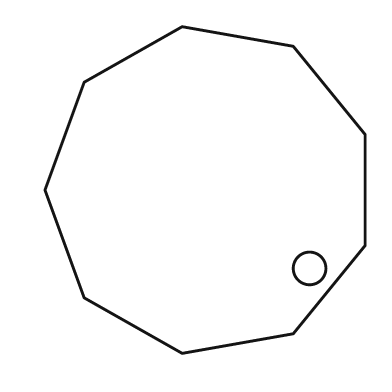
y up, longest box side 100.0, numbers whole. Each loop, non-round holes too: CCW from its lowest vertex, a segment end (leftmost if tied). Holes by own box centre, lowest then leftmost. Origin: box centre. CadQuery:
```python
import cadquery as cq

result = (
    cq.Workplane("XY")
    .moveTo(-7.0, -50.0)
    .lineTo(27.0, -44.0)
    .lineTo(49.0, -17.0)
    .lineTo(49.0, 17.0)
    .lineTo(27.0, 44.0)
    .lineTo(-7.0, 50.0)
    .lineTo(-37.0, 33.0)
    .lineTo(-49.0, 0.0)
    .lineTo(-37.0, -33.0)
    .close()
    .moveTo(32.0, -24.0)
    .circle(5.0)
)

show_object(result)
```